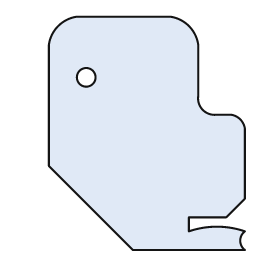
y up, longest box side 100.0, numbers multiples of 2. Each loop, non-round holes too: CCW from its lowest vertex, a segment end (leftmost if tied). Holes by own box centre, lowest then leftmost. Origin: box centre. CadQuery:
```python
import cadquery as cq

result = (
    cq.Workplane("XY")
    .moveTo(-6.0, -50.0)
    .lineTo(42.0, -50.0)
    .threePointArc((40.0, -46.0), (42.0, -42.0))
    .threePointArc((30.0, -40.0), (18.0, -42.0))
    .lineTo(18.0, -36.0)
    .lineTo(34.0, -36.0)
    .lineTo(42.0, -28.0)
    .lineTo(42.0, 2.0)
    .threePointArc((40.0, 6.0), (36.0, 8.0))
    .lineTo(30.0, 8.0)
    .threePointArc((24.0, 10.0), (22.0, 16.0))
    .lineTo(22.0, 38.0)
    .threePointArc((18.0, 46.0), (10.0, 50.0))
    .lineTo(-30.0, 50.0)
    .threePointArc((-38.0, 46.0), (-42.0, 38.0))
    .lineTo(-42.0, -14.0)
    .close()
    .moveTo(-26.0, 24.0)
    .circle(4.0)
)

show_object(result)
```